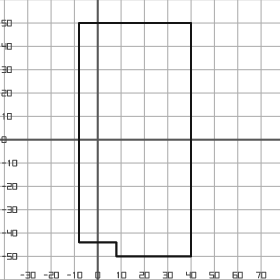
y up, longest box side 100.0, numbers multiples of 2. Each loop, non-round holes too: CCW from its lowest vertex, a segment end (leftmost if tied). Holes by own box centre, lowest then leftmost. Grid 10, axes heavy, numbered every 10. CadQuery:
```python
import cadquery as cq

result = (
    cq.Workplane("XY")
    .moveTo(8.0, -50.0)
    .lineTo(40.0, -50.0)
    .lineTo(40.0, 50.0)
    .lineTo(-8.0, 50.0)
    .lineTo(-8.0, -44.0)
    .lineTo(8.0, -44.0)
    .close()
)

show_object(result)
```